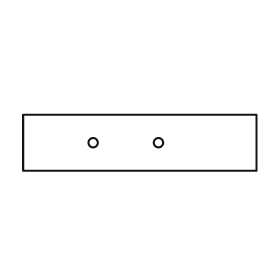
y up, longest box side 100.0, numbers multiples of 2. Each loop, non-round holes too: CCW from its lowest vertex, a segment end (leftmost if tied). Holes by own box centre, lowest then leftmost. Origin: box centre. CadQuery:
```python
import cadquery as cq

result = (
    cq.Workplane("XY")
    .moveTo(-50.0, -12.0)
    .lineTo(50.0, -12.0)
    .lineTo(50.0, 12.0)
    .lineTo(-50.0, 12.0)
    .close()
    .moveTo(-20.0, 0.0)
    .circle(2.0)
    .moveTo(8.0, 0.0)
    .circle(2.0)
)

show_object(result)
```